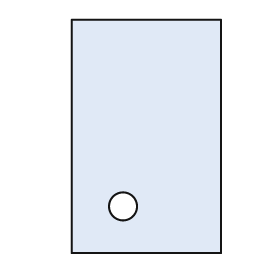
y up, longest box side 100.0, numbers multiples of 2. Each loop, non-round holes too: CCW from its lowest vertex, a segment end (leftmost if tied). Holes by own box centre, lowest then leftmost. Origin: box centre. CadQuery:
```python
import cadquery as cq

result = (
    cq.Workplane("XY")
    .moveTo(-32.0, -50.0)
    .lineTo(32.0, -50.0)
    .lineTo(32.0, 50.0)
    .lineTo(-32.0, 50.0)
    .close()
    .moveTo(-10.0, -30.0)
    .circle(6.0)
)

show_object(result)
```